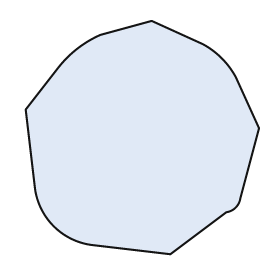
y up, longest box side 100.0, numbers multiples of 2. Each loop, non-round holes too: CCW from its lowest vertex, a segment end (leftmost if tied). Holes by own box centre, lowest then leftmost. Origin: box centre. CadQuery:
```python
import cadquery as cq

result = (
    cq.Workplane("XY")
    .moveTo(12.0, -50.0)
    .lineTo(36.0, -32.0)
    .threePointArc((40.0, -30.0), (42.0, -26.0))
    .lineTo(50.0, 4.0)
    .lineTo(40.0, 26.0)
    .threePointArc((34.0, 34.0), (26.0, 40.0))
    .lineTo(4.0, 50.0)
    .lineTo(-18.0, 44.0)
    .threePointArc((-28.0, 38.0), (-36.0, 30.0))
    .lineTo(-50.0, 12.0)
    .lineTo(-46.0, -22.0)
    .threePointArc((-38.0, -38.0), (-22.0, -46.0))
    .close()
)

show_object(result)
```